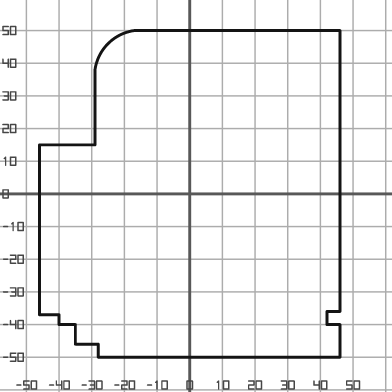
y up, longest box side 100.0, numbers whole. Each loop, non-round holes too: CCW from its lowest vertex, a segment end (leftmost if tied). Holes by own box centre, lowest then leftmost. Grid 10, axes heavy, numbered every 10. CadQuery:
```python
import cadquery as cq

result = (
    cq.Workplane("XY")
    .moveTo(-28.0, -50.0)
    .lineTo(46.0, -50.0)
    .lineTo(46.0, -40.0)
    .lineTo(42.0, -40.0)
    .lineTo(42.0, -36.0)
    .lineTo(46.0, -36.0)
    .lineTo(46.0, 50.0)
    .lineTo(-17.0, 50.0)
    .threePointArc((-25.0, 46.0), (-29.0, 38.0))
    .lineTo(-29.0, 15.0)
    .lineTo(-46.0, 15.0)
    .lineTo(-46.0, -37.0)
    .lineTo(-40.0, -37.0)
    .lineTo(-40.0, -40.0)
    .lineTo(-35.0, -40.0)
    .lineTo(-35.0, -46.0)
    .lineTo(-28.0, -46.0)
    .close()
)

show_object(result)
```